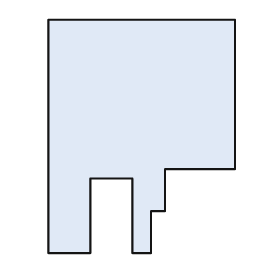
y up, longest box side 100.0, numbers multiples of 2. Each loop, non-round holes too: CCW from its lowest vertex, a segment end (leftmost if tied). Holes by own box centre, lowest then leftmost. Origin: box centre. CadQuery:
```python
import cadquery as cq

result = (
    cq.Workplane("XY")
    .moveTo(-40.0, -50.0)
    .lineTo(-22.0, -50.0)
    .lineTo(-22.0, -18.0)
    .lineTo(-4.0, -18.0)
    .lineTo(-4.0, -50.0)
    .lineTo(4.0, -50.0)
    .lineTo(4.0, -32.0)
    .lineTo(10.0, -32.0)
    .lineTo(10.0, -14.0)
    .lineTo(40.0, -14.0)
    .lineTo(40.0, 50.0)
    .lineTo(-40.0, 50.0)
    .close()
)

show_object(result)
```